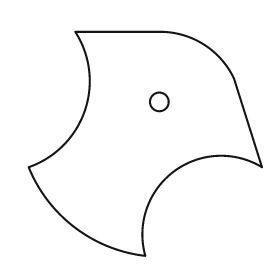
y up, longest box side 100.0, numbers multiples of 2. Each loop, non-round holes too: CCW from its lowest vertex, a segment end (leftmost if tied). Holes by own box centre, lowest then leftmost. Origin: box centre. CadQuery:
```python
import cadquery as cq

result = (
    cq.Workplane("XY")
    .moveTo(0.0, -48.0)
    .threePointArc((12.0, -12.0), (50.0, -10.0))
    .lineTo(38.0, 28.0)
    .threePointArc((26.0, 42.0), (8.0, 48.0))
    .lineTo(-30.0, 48.0)
    .threePointArc((-26.0, 14.0), (-50.0, -10.0))
    .threePointArc((-30.0, -36.0), (0.0, -48.0))
    .close()
    .moveTo(6.0, 18.0)
    .circle(4.0)
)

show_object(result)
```